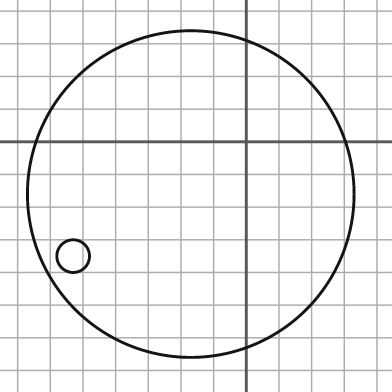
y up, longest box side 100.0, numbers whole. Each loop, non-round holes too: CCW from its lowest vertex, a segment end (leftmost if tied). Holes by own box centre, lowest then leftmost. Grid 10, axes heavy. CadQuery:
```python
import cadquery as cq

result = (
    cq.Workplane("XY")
    .moveTo(-17.0, -16.0)
    .circle(50.0)
    .moveTo(-53.0, -35.0)
    .circle(5.0)
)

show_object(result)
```